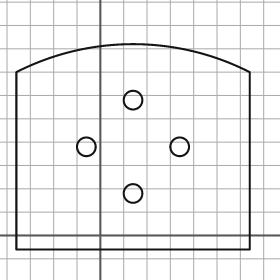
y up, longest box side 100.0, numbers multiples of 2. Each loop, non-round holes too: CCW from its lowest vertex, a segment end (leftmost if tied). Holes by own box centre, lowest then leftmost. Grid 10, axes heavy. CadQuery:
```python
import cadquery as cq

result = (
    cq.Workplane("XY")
    .moveTo(-36.0, -6.0)
    .lineTo(64.0, -6.0)
    .lineTo(64.0, 70.0)
    .threePointArc((14.0, 82.0), (-36.0, 70.0))
    .close()
    .moveTo(14.0, 18.0)
    .circle(4.0)
    .moveTo(-6.0, 38.0)
    .circle(4.0)
    .moveTo(34.0, 38.0)
    .circle(4.0)
    .moveTo(14.0, 58.0)
    .circle(4.0)
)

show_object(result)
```